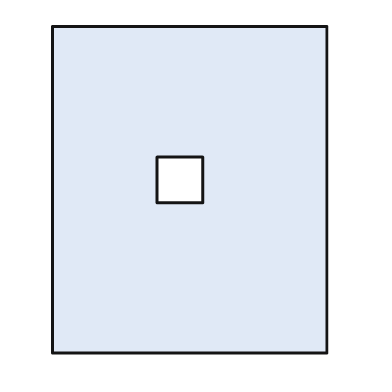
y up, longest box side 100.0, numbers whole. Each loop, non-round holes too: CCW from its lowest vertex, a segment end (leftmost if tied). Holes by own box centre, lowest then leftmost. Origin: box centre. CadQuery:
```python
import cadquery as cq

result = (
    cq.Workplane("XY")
    .moveTo(-42.0, -50.0)
    .lineTo(42.0, -50.0)
    .lineTo(42.0, 50.0)
    .lineTo(-42.0, 50.0)
    .close()
    .moveTo(-10.0, -4.0)
    .lineTo(4.0, -4.0)
    .lineTo(4.0, 10.0)
    .lineTo(-10.0, 10.0)
    .close()
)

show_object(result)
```